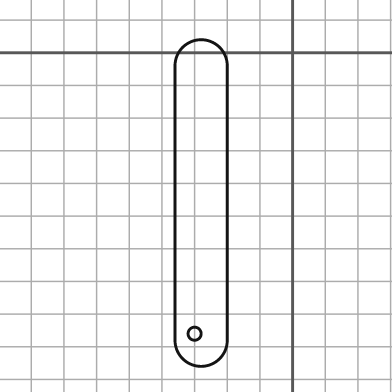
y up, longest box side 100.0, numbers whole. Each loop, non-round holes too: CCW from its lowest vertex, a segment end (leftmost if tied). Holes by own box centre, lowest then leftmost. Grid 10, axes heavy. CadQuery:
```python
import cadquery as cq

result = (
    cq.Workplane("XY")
    .moveTo(-36.0, -88.0)
    .threePointArc((-28.0, -96.0), (-20.0, -88.0))
    .lineTo(-20.0, -4.0)
    .threePointArc((-28.0, 4.0), (-36.0, -4.0))
    .close()
    .moveTo(-30.0, -86.0)
    .circle(2.0)
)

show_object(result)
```